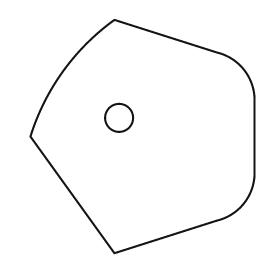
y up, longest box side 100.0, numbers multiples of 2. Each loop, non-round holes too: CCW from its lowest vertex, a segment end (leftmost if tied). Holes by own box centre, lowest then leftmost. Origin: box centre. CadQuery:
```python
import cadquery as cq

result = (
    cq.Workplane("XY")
    .moveTo(-12.0, -50.0)
    .lineTo(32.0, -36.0)
    .threePointArc((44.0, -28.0), (48.0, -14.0))
    .lineTo(48.0, 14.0)
    .threePointArc((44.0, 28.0), (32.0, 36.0))
    .lineTo(-12.0, 50.0)
    .threePointArc((-34.0, 28.0), (-48.0, 0.0))
    .close()
    .moveTo(-10.0, 8.0)
    .circle(6.0)
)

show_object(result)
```